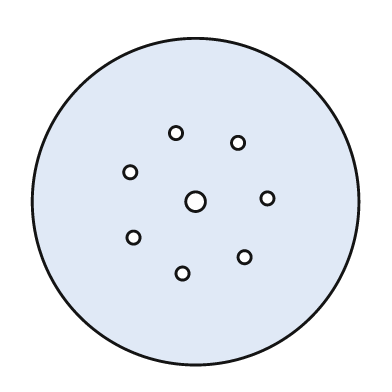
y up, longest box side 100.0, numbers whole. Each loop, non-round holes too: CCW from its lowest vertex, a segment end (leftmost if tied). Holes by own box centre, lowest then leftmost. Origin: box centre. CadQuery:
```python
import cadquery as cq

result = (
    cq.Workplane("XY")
    .moveTo(0.0, 0.0)
    .circle(50.0)
    .moveTo(-4.0, -22.0)
    .circle(2.0)
    .moveTo(15.0, -17.0)
    .circle(2.0)
    .moveTo(-19.0, -11.0)
    .circle(2.0)
    .moveTo(0.0, 0.0)
    .circle(3.0)
    .moveTo(22.0, 1.0)
    .circle(2.0)
    .moveTo(-20.0, 9.0)
    .circle(2.0)
    .moveTo(13.0, 18.0)
    .circle(2.0)
    .moveTo(-6.0, 21.0)
    .circle(2.0)
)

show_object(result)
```